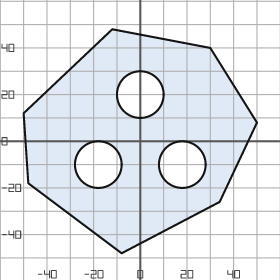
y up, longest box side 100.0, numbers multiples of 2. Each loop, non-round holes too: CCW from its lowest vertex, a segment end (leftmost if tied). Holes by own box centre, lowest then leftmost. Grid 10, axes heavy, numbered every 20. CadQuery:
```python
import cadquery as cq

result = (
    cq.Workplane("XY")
    .moveTo(-8.0, -48.0)
    .lineTo(34.0, -26.0)
    .lineTo(50.0, 8.0)
    .lineTo(30.0, 40.0)
    .lineTo(-12.0, 48.0)
    .lineTo(-50.0, 12.0)
    .lineTo(-48.0, -18.0)
    .close()
    .moveTo(-18.0, -10.0)
    .circle(10.0)
    .moveTo(18.0, -10.0)
    .circle(10.0)
    .moveTo(0.0, 20.0)
    .circle(10.0)
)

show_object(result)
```